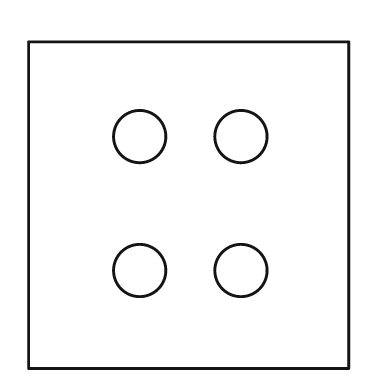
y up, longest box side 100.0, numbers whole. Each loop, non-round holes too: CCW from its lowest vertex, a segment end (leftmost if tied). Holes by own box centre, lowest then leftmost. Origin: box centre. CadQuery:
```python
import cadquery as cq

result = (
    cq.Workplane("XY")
    .moveTo(-49.0, -50.0)
    .lineTo(49.0, -50.0)
    .lineTo(49.0, 50.0)
    .lineTo(-49.0, 50.0)
    .close()
    .moveTo(-15.0, -20.0)
    .circle(8.0)
    .moveTo(16.0, -20.0)
    .circle(8.0)
    .moveTo(-15.0, 21.0)
    .circle(8.0)
    .moveTo(16.0, 21.0)
    .circle(8.0)
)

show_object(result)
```